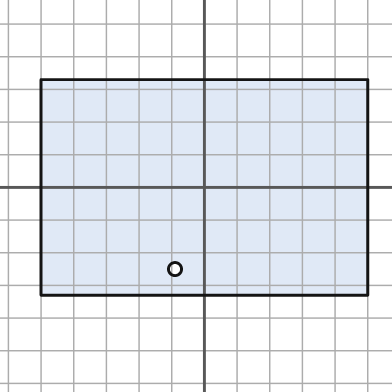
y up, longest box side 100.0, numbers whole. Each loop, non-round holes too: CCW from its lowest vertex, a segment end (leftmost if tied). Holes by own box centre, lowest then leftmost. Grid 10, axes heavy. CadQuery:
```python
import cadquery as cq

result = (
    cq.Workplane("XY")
    .moveTo(-50.0, -33.0)
    .lineTo(50.0, -33.0)
    .lineTo(50.0, 33.0)
    .lineTo(-50.0, 33.0)
    .close()
    .moveTo(-9.0, -25.0)
    .circle(2.0)
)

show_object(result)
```